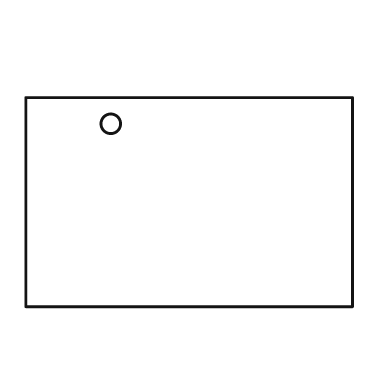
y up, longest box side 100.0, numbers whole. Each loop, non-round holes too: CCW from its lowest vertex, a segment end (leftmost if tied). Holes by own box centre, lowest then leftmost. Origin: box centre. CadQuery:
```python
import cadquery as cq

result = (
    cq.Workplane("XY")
    .moveTo(-50.0, -32.0)
    .lineTo(50.0, -32.0)
    .lineTo(50.0, 32.0)
    .lineTo(-50.0, 32.0)
    .close()
    .moveTo(-24.0, 24.0)
    .circle(3.0)
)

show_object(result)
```